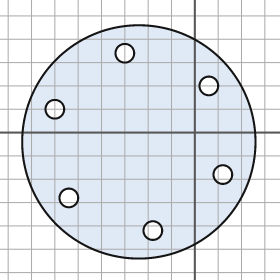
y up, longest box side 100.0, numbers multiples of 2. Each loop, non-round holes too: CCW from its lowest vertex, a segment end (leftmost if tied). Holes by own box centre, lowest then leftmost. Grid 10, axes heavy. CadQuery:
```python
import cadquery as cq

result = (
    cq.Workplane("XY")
    .moveTo(-24.0, -4.0)
    .circle(50.0)
    .moveTo(-18.0, -42.0)
    .circle(4.0)
    .moveTo(-54.0, -28.0)
    .circle(4.0)
    .moveTo(12.0, -18.0)
    .circle(4.0)
    .moveTo(-60.0, 10.0)
    .circle(4.0)
    .moveTo(6.0, 20.0)
    .circle(4.0)
    .moveTo(-30.0, 34.0)
    .circle(4.0)
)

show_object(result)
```